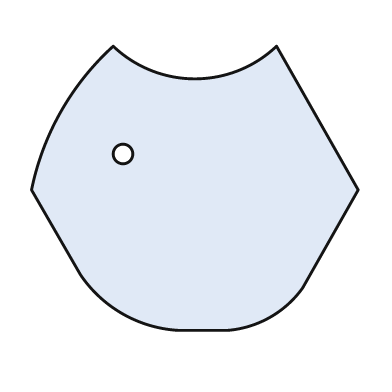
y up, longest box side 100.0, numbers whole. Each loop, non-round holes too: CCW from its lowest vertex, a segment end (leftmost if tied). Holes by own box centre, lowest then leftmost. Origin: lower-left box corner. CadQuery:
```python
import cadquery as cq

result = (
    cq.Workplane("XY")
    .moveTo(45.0, 0.0)
    .lineTo(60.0, 0.0)
    .threePointArc((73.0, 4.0), (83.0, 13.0))
    .lineTo(100.0, 43.0)
    .lineTo(75.0, 87.0)
    .threePointArc((50.0, 77.0), (25.0, 87.0))
    .threePointArc((9.0, 67.0), (0.0, 43.0))
    .lineTo(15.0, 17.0)
    .threePointArc((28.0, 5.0), (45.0, 0.0))
    .close()
    .moveTo(28.0, 54.0)
    .circle(3.0)
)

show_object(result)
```